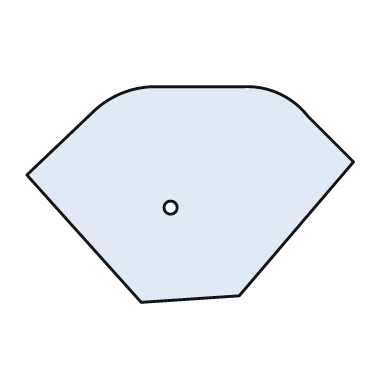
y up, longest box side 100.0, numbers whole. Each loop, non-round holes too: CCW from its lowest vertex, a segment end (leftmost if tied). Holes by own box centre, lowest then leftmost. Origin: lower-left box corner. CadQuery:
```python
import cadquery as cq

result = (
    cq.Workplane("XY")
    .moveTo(35.0, 0.0)
    .lineTo(65.0, 2.0)
    .lineTo(100.0, 43.0)
    .lineTo(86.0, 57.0)
    .threePointArc((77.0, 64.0), (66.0, 66.0))
    .lineTo(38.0, 66.0)
    .threePointArc((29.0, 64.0), (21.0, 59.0))
    .lineTo(0.0, 39.0)
    .close()
    .moveTo(44.0, 29.0)
    .circle(2.0)
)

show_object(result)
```